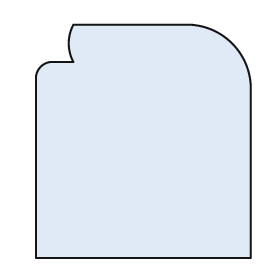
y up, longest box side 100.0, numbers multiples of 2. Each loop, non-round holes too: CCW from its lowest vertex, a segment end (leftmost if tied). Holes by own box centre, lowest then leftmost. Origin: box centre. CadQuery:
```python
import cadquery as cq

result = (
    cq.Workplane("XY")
    .moveTo(-46.0, -50.0)
    .lineTo(46.0, -50.0)
    .lineTo(46.0, 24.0)
    .threePointArc((38.0, 42.0), (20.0, 50.0))
    .lineTo(-30.0, 50.0)
    .threePointArc((-32.0, 42.0), (-30.0, 34.0))
    .lineTo(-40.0, 34.0)
    .threePointArc((-44.0, 32.0), (-46.0, 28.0))
    .close()
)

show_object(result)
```